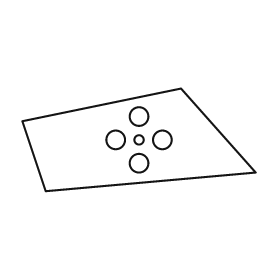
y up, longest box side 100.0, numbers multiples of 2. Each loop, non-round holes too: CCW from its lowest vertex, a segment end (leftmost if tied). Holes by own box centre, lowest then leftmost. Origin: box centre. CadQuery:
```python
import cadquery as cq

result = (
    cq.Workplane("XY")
    .moveTo(-40.0, -22.0)
    .lineTo(50.0, -14.0)
    .lineTo(18.0, 22.0)
    .lineTo(-50.0, 8.0)
    .close()
    .moveTo(0.0, -10.0)
    .circle(4.0)
    .moveTo(-10.0, 0.0)
    .circle(4.0)
    .moveTo(0.0, 0.0)
    .circle(2.0)
    .moveTo(10.0, 0.0)
    .circle(4.0)
    .moveTo(0.0, 10.0)
    .circle(4.0)
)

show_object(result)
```